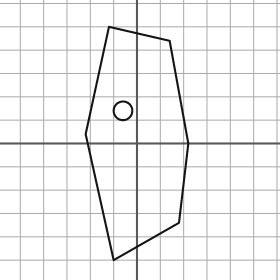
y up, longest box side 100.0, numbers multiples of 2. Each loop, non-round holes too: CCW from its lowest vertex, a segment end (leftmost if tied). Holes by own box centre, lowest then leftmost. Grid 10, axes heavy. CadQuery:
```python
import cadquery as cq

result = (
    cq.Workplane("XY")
    .moveTo(-10.0, -50.0)
    .lineTo(18.0, -34.0)
    .lineTo(22.0, 0.0)
    .lineTo(14.0, 44.0)
    .lineTo(-12.0, 50.0)
    .lineTo(-22.0, 4.0)
    .close()
    .moveTo(-6.0, 14.0)
    .circle(4.0)
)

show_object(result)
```